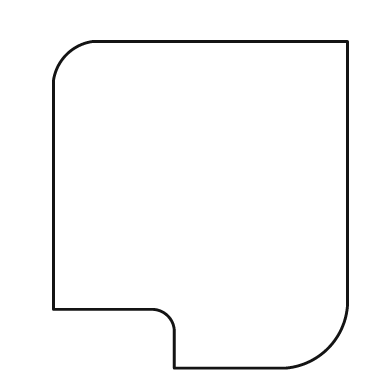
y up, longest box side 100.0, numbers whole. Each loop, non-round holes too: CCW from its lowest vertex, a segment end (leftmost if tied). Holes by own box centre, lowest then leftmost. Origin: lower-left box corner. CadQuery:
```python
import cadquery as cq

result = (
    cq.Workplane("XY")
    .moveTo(37.0, 0.0)
    .lineTo(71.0, 0.0)
    .threePointArc((84.0, 6.0), (90.0, 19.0))
    .lineTo(90.0, 100.0)
    .lineTo(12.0, 100.0)
    .threePointArc((4.0, 96.0), (0.0, 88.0))
    .lineTo(0.0, 18.0)
    .lineTo(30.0, 18.0)
    .threePointArc((35.0, 16.0), (37.0, 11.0))
    .close()
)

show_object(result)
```